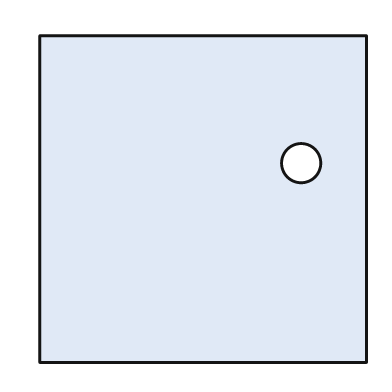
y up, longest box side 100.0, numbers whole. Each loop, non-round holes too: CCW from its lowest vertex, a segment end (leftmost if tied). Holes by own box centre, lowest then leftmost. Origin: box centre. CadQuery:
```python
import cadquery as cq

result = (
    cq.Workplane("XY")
    .moveTo(-50.0, -50.0)
    .lineTo(50.0, -50.0)
    .lineTo(50.0, 50.0)
    .lineTo(-50.0, 50.0)
    .close()
    .moveTo(30.0, 11.0)
    .circle(6.0)
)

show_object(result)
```